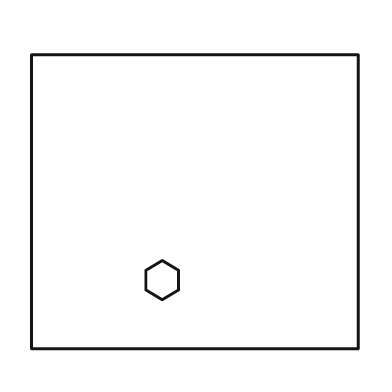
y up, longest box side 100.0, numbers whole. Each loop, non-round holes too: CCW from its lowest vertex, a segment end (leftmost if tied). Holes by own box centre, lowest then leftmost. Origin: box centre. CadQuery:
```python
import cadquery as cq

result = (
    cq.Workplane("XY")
    .moveTo(-50.0, -45.0)
    .lineTo(50.0, -45.0)
    .lineTo(50.0, 45.0)
    .lineTo(-50.0, 45.0)
    .close()
    .moveTo(-10.0, -30.0)
    .lineTo(-5.0, -27.0)
    .lineTo(-5.0, -21.0)
    .lineTo(-10.0, -18.0)
    .lineTo(-15.0, -21.0)
    .lineTo(-15.0, -27.0)
    .close()
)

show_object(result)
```